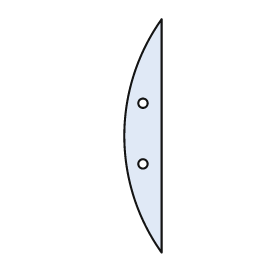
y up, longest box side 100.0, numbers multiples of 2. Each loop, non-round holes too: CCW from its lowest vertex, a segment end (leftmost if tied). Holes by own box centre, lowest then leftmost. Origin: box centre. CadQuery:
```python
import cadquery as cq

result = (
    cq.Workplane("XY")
    .moveTo(8.0, -50.0)
    .lineTo(8.0, 50.0)
    .threePointArc((-8.0, 0.0), (8.0, -50.0))
    .close()
    .moveTo(0.0, -12.0)
    .circle(2.0)
    .moveTo(0.0, 14.0)
    .circle(2.0)
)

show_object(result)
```